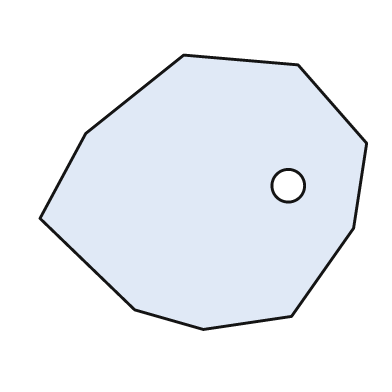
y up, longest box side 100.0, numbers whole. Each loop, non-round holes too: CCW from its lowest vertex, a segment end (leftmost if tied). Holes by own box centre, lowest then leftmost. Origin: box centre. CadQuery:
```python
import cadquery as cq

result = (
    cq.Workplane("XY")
    .moveTo(0.0, -42.0)
    .lineTo(27.0, -38.0)
    .lineTo(46.0, -11.0)
    .lineTo(50.0, 15.0)
    .lineTo(29.0, 39.0)
    .lineTo(-6.0, 42.0)
    .lineTo(-36.0, 18.0)
    .lineTo(-50.0, -8.0)
    .lineTo(-21.0, -36.0)
    .close()
    .moveTo(26.0, 2.0)
    .circle(5.0)
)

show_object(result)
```